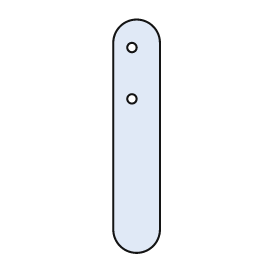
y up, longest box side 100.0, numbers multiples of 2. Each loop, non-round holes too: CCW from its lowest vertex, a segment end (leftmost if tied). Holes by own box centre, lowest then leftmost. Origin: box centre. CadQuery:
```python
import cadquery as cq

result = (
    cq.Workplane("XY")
    .moveTo(-10.0, -40.0)
    .threePointArc((0.0, -50.0), (10.0, -40.0))
    .lineTo(10.0, 40.0)
    .threePointArc((0.0, 50.0), (-10.0, 40.0))
    .close()
    .moveTo(-2.0, 16.0)
    .circle(2.0)
    .moveTo(-2.0, 38.0)
    .circle(2.0)
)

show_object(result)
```